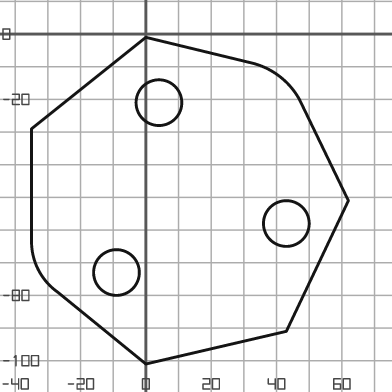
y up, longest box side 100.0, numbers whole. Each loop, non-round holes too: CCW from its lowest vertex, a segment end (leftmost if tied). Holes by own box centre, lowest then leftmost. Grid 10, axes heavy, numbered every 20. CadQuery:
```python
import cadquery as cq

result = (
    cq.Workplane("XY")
    .moveTo(0.0, -101.0)
    .lineTo(43.0, -91.0)
    .lineTo(62.0, -51.0)
    .lineTo(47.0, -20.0)
    .threePointArc((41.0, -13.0), (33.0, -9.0))
    .lineTo(0.0, -1.0)
    .lineTo(-35.0, -29.0)
    .lineTo(-35.0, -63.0)
    .threePointArc((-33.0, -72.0), (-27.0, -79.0))
    .close()
    .moveTo(-9.0, -73.0)
    .circle(7.0)
    .moveTo(43.0, -58.0)
    .circle(7.0)
    .moveTo(4.0, -21.0)
    .circle(7.0)
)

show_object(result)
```